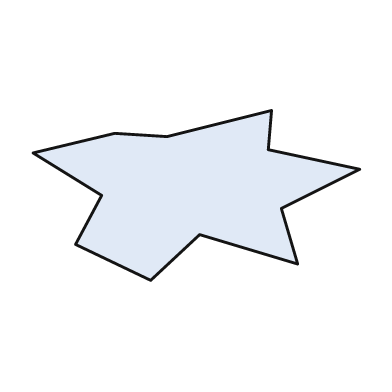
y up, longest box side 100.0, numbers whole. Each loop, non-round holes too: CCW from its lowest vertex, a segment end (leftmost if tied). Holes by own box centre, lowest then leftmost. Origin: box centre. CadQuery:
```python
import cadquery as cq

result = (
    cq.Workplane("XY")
    .moveTo(-14.0, -26.0)
    .lineTo(1.0, -12.0)
    .lineTo(31.0, -21.0)
    .lineTo(26.0, -4.0)
    .lineTo(50.0, 8.0)
    .lineTo(22.0, 14.0)
    .lineTo(23.0, 26.0)
    .lineTo(-9.0, 18.0)
    .lineTo(-25.0, 19.0)
    .lineTo(-50.0, 13.0)
    .lineTo(-29.0, 0.0)
    .lineTo(-37.0, -15.0)
    .close()
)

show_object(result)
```